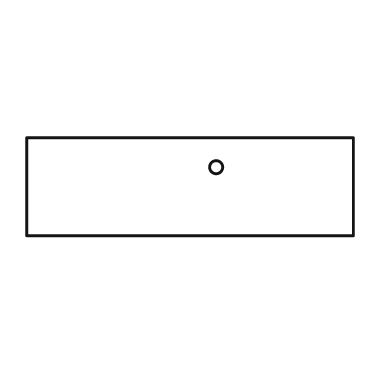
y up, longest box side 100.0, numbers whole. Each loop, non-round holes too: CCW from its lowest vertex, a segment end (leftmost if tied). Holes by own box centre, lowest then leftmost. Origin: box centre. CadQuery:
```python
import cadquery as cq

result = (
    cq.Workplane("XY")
    .moveTo(-50.0, -15.0)
    .lineTo(50.0, -15.0)
    .lineTo(50.0, 15.0)
    .lineTo(-50.0, 15.0)
    .close()
    .moveTo(8.0, 6.0)
    .circle(2.0)
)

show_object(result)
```